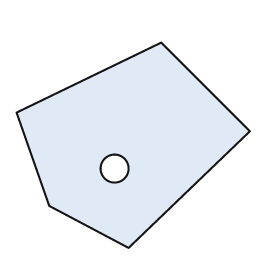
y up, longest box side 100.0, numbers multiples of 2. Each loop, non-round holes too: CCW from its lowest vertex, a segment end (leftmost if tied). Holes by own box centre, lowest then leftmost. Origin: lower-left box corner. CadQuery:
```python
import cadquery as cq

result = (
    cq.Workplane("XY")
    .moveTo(48.0, 0.0)
    .lineTo(100.0, 50.0)
    .lineTo(62.0, 88.0)
    .lineTo(0.0, 58.0)
    .lineTo(14.0, 18.0)
    .close()
    .moveTo(42.0, 34.0)
    .circle(6.0)
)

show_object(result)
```